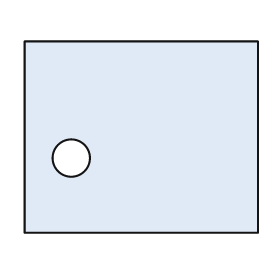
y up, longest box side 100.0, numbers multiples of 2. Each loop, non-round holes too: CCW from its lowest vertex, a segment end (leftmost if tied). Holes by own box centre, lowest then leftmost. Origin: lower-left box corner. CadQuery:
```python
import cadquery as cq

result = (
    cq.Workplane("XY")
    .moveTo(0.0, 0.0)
    .lineTo(100.0, 0.0)
    .lineTo(100.0, 82.0)
    .lineTo(0.0, 82.0)
    .close()
    .moveTo(20.0, 32.0)
    .circle(8.0)
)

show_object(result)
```